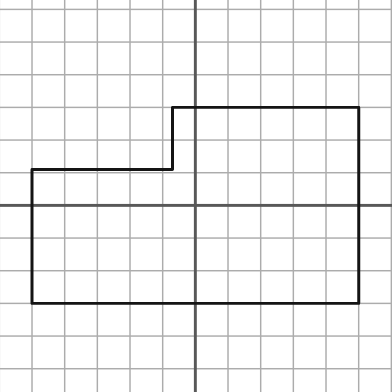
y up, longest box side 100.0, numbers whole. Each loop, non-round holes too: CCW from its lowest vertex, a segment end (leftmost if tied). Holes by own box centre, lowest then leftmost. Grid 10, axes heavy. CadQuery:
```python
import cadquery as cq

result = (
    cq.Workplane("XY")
    .moveTo(-50.0, -30.0)
    .lineTo(50.0, -30.0)
    .lineTo(50.0, 30.0)
    .lineTo(-7.0, 30.0)
    .lineTo(-7.0, 11.0)
    .lineTo(-50.0, 11.0)
    .close()
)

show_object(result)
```